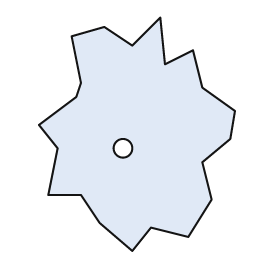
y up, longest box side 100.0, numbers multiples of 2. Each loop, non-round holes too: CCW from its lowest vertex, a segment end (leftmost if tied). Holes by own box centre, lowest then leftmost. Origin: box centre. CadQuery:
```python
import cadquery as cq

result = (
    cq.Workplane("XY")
    .moveTo(-2.0, -50.0)
    .lineTo(6.0, -40.0)
    .lineTo(22.0, -44.0)
    .lineTo(32.0, -28.0)
    .lineTo(28.0, -12.0)
    .lineTo(40.0, -2.0)
    .lineTo(42.0, 10.0)
    .lineTo(28.0, 20.0)
    .lineTo(24.0, 36.0)
    .lineTo(12.0, 30.0)
    .lineTo(10.0, 50.0)
    .lineTo(-2.0, 38.0)
    .lineTo(-14.0, 46.0)
    .lineTo(-28.0, 42.0)
    .lineTo(-24.0, 22.0)
    .lineTo(-26.0, 16.0)
    .lineTo(-42.0, 4.0)
    .lineTo(-34.0, -6.0)
    .lineTo(-38.0, -26.0)
    .lineTo(-24.0, -26.0)
    .lineTo(-16.0, -38.0)
    .close()
    .moveTo(-6.0, -6.0)
    .circle(4.0)
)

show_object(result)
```